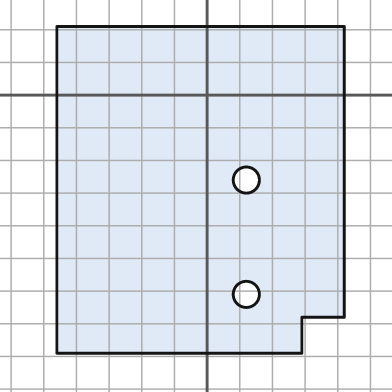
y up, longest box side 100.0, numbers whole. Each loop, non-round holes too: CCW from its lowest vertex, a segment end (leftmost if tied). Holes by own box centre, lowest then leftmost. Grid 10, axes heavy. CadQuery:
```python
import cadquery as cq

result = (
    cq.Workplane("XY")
    .moveTo(-46.0, -79.0)
    .lineTo(29.0, -79.0)
    .lineTo(29.0, -68.0)
    .lineTo(42.0, -68.0)
    .lineTo(42.0, 21.0)
    .lineTo(-46.0, 21.0)
    .close()
    .moveTo(12.0, -61.0)
    .circle(4.0)
    .moveTo(12.0, -26.0)
    .circle(4.0)
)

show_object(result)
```